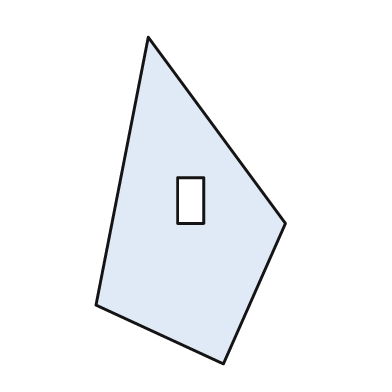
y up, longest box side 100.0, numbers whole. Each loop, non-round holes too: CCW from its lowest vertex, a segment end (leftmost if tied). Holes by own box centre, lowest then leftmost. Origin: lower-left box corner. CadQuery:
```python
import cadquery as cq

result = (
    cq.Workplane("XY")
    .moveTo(39.0, 0.0)
    .lineTo(58.0, 43.0)
    .lineTo(16.0, 100.0)
    .lineTo(0.0, 18.0)
    .close()
    .moveTo(25.0, 43.0)
    .lineTo(33.0, 43.0)
    .lineTo(33.0, 57.0)
    .lineTo(25.0, 57.0)
    .close()
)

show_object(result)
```